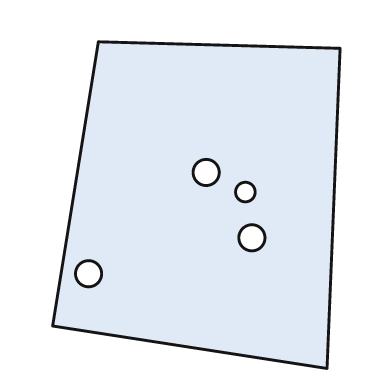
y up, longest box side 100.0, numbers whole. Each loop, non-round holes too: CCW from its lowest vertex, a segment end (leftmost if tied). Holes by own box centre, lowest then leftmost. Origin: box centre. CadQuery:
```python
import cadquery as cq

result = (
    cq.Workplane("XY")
    .moveTo(40.0, -50.0)
    .lineTo(44.0, 48.0)
    .lineTo(-30.0, 50.0)
    .lineTo(-44.0, -37.0)
    .close()
    .moveTo(-33.0, -21.0)
    .circle(4.0)
    .moveTo(17.0, -10.0)
    .circle(4.0)
    .moveTo(15.0, 4.0)
    .circle(3.0)
    .moveTo(3.0, 10.0)
    .circle(4.0)
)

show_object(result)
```